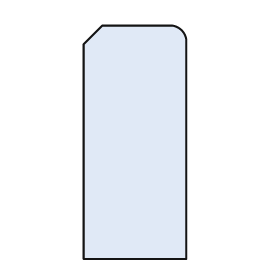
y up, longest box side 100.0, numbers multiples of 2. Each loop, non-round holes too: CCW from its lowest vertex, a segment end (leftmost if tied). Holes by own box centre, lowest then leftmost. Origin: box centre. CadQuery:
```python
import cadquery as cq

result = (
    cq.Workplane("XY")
    .moveTo(-22.0, -50.0)
    .lineTo(22.0, -50.0)
    .lineTo(22.0, 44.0)
    .threePointArc((20.0, 48.0), (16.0, 50.0))
    .lineTo(-14.0, 50.0)
    .lineTo(-22.0, 42.0)
    .close()
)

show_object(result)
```